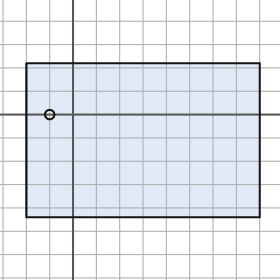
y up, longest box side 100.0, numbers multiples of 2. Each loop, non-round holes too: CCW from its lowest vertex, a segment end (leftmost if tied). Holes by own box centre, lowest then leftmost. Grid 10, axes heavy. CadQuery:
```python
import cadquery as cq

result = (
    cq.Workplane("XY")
    .moveTo(-20.0, -44.0)
    .lineTo(80.0, -44.0)
    .lineTo(80.0, 22.0)
    .lineTo(-20.0, 22.0)
    .close()
    .moveTo(-10.0, 0.0)
    .circle(2.0)
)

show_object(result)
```